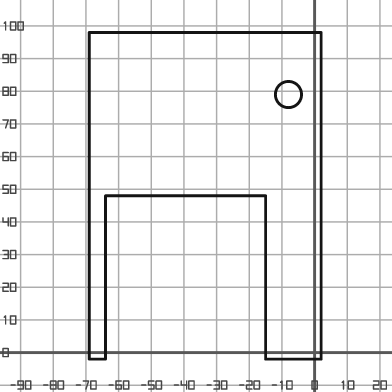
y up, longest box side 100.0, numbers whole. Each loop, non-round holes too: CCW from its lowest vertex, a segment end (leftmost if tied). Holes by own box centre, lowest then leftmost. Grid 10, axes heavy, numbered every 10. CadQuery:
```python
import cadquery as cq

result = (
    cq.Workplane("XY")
    .moveTo(-69.0, -2.0)
    .lineTo(-64.0, -2.0)
    .lineTo(-64.0, 48.0)
    .lineTo(-15.0, 48.0)
    .lineTo(-15.0, -2.0)
    .lineTo(2.0, -2.0)
    .lineTo(2.0, 98.0)
    .lineTo(-69.0, 98.0)
    .close()
    .moveTo(-8.0, 79.0)
    .circle(4.0)
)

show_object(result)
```